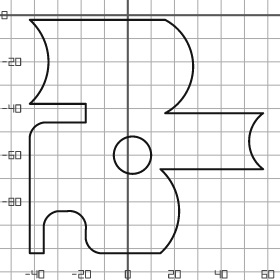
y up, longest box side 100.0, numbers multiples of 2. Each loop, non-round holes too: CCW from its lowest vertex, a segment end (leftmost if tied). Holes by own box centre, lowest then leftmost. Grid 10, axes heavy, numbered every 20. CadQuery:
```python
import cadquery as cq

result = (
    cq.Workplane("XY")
    .moveTo(-42.0, -102.0)
    .lineTo(-36.0, -102.0)
    .lineTo(-36.0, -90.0)
    .threePointArc((-34.0, -86.0), (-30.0, -84.0))
    .lineTo(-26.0, -84.0)
    .threePointArc((-20.0, -86.0), (-18.0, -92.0))
    .lineTo(-18.0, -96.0)
    .threePointArc((-16.0, -100.0), (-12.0, -102.0))
    .lineTo(14.0, -102.0)
    .threePointArc((22.0, -84.0), (14.0, -66.0))
    .lineTo(58.0, -66.0)
    .threePointArc((52.0, -54.0), (58.0, -42.0))
    .lineTo(16.0, -42.0)
    .threePointArc((28.0, -22.0), (16.0, -2.0))
    .lineTo(-42.0, -2.0)
    .threePointArc((-34.0, -20.0), (-42.0, -38.0))
    .lineTo(-18.0, -38.0)
    .lineTo(-18.0, -46.0)
    .lineTo(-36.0, -46.0)
    .threePointArc((-40.0, -48.0), (-42.0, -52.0))
    .close()
    .moveTo(2.0, -60.0)
    .circle(8.0)
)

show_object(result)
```